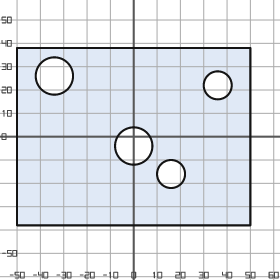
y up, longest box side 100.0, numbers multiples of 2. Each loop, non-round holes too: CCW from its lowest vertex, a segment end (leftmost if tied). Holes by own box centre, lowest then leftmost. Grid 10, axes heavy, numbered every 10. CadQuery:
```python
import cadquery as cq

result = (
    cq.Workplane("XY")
    .moveTo(-50.0, -38.0)
    .lineTo(50.0, -38.0)
    .lineTo(50.0, 38.0)
    .lineTo(-50.0, 38.0)
    .close()
    .moveTo(16.0, -16.0)
    .circle(6.0)
    .moveTo(0.0, -4.0)
    .circle(8.0)
    .moveTo(36.0, 22.0)
    .circle(6.0)
    .moveTo(-34.0, 26.0)
    .circle(8.0)
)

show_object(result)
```